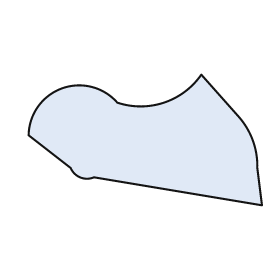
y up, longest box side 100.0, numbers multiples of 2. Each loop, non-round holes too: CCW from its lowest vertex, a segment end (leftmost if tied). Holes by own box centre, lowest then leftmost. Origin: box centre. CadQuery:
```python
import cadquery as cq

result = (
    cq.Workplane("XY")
    .moveTo(50.0, -28.0)
    .lineTo(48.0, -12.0)
    .threePointArc((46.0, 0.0), (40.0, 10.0))
    .lineTo(24.0, 28.0)
    .threePointArc((8.0, 16.0), (-12.0, 16.0))
    .threePointArc((-36.0, 22.0), (-50.0, 2.0))
    .lineTo(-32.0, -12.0)
    .threePointArc((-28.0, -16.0), (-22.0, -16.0))
    .close()
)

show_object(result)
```